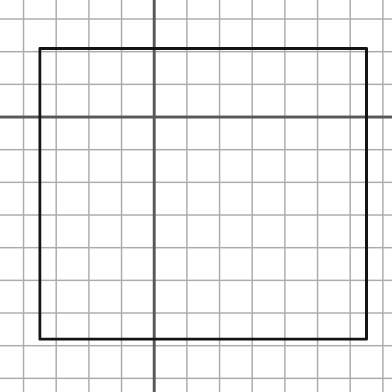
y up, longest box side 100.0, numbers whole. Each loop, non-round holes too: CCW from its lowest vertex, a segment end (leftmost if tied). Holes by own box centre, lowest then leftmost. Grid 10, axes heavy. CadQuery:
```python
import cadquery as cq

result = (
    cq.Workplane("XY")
    .moveTo(-35.0, -68.0)
    .lineTo(65.0, -68.0)
    .lineTo(65.0, 21.0)
    .lineTo(-35.0, 21.0)
    .close()
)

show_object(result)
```